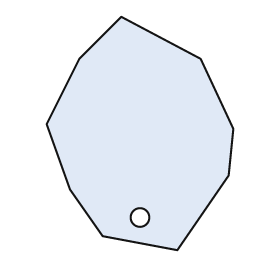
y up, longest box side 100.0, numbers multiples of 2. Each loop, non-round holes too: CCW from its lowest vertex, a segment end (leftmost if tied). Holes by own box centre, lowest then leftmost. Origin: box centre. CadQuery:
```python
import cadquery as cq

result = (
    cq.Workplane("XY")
    .moveTo(16.0, -50.0)
    .lineTo(38.0, -18.0)
    .lineTo(40.0, 2.0)
    .lineTo(26.0, 32.0)
    .lineTo(-8.0, 50.0)
    .lineTo(-26.0, 32.0)
    .lineTo(-40.0, 4.0)
    .lineTo(-30.0, -24.0)
    .lineTo(-16.0, -44.0)
    .close()
    .moveTo(0.0, -36.0)
    .circle(4.0)
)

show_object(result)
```